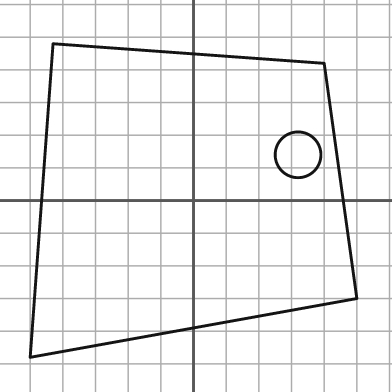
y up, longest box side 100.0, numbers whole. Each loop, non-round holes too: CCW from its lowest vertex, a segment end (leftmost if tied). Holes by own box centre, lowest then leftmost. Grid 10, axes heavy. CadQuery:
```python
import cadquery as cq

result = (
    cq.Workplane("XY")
    .moveTo(-50.0, -48.0)
    .lineTo(50.0, -30.0)
    .lineTo(40.0, 42.0)
    .lineTo(-43.0, 48.0)
    .close()
    .moveTo(32.0, 14.0)
    .circle(7.0)
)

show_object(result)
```